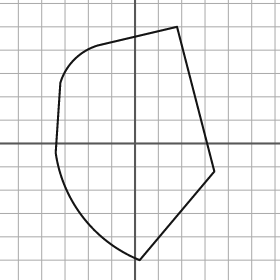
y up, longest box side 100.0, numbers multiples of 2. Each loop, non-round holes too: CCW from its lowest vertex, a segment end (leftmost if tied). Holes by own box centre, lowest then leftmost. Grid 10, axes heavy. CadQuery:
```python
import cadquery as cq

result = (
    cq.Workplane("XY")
    .moveTo(2.0, -50.0)
    .lineTo(34.0, -12.0)
    .lineTo(18.0, 50.0)
    .lineTo(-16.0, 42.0)
    .threePointArc((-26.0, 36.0), (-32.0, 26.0))
    .lineTo(-34.0, -4.0)
    .threePointArc((-22.0, -32.0), (2.0, -50.0))
    .close()
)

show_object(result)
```